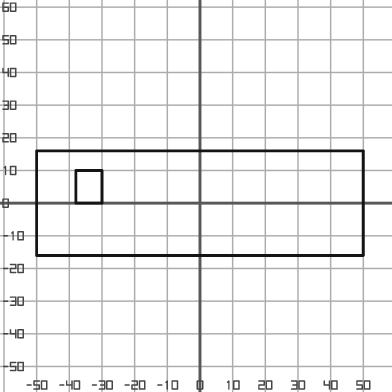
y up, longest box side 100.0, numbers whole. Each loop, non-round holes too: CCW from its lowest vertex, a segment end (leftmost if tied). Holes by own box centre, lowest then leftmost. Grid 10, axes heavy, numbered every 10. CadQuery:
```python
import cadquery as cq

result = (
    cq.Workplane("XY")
    .moveTo(-50.0, -16.0)
    .lineTo(50.0, -16.0)
    .lineTo(50.0, 16.0)
    .lineTo(-50.0, 16.0)
    .close()
    .moveTo(-38.0, 0.0)
    .lineTo(-30.0, 0.0)
    .lineTo(-30.0, 10.0)
    .lineTo(-38.0, 10.0)
    .close()
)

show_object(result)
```